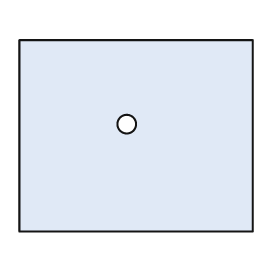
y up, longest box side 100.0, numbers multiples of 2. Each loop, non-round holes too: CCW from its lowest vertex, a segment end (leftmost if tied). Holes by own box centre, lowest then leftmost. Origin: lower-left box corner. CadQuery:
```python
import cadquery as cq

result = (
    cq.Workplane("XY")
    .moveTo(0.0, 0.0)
    .lineTo(100.0, 0.0)
    .lineTo(100.0, 82.0)
    .lineTo(0.0, 82.0)
    .close()
    .moveTo(46.0, 46.0)
    .circle(4.0)
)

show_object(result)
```